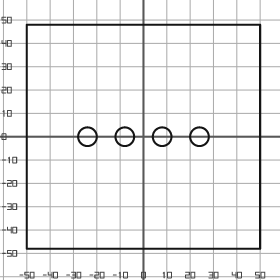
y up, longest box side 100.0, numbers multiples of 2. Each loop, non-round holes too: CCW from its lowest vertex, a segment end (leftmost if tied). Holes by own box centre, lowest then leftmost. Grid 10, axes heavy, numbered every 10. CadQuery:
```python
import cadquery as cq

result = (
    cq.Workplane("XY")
    .moveTo(-50.0, -48.0)
    .lineTo(50.0, -48.0)
    .lineTo(50.0, 48.0)
    .lineTo(-50.0, 48.0)
    .close()
    .moveTo(-24.0, 0.0)
    .circle(4.0)
    .moveTo(-8.0, 0.0)
    .circle(4.0)
    .moveTo(8.0, 0.0)
    .circle(4.0)
    .moveTo(24.0, 0.0)
    .circle(4.0)
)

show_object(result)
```